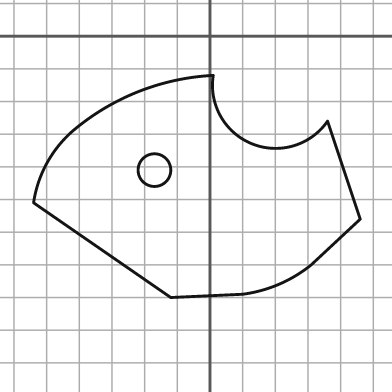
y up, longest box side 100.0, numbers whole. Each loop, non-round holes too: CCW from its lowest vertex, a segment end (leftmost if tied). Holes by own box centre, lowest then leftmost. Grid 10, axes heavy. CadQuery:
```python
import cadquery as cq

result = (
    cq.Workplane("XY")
    .moveTo(-12.0, -80.0)
    .lineTo(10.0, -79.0)
    .threePointArc((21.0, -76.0), (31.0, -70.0))
    .lineTo(46.0, -56.0)
    .lineTo(36.0, -26.0)
    .threePointArc((13.0, -33.0), (1.0, -12.0))
    .threePointArc((-22.0, -17.0), (-42.0, -29.0))
    .threePointArc((-50.0, -39.0), (-54.0, -51.0))
    .close()
    .moveTo(-17.0, -41.0)
    .circle(5.0)
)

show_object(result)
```